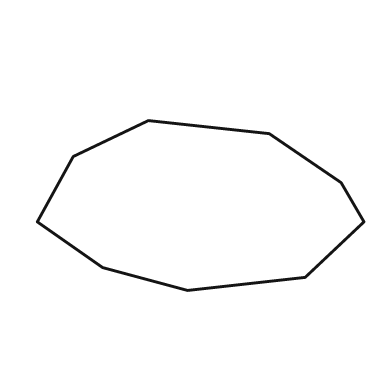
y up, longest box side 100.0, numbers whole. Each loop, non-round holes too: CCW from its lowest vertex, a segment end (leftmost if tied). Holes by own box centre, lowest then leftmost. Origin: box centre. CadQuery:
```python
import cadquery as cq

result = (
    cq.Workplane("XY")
    .moveTo(-4.0, -26.0)
    .lineTo(32.0, -22.0)
    .lineTo(50.0, -5.0)
    .lineTo(43.0, 7.0)
    .lineTo(21.0, 22.0)
    .lineTo(-16.0, 26.0)
    .lineTo(-39.0, 15.0)
    .lineTo(-50.0, -5.0)
    .lineTo(-30.0, -19.0)
    .close()
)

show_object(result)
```